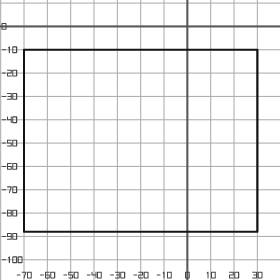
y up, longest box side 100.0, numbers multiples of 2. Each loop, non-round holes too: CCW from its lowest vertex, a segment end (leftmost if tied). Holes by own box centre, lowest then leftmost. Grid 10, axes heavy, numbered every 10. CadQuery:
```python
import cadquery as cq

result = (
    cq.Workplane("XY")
    .moveTo(-70.0, -88.0)
    .lineTo(30.0, -88.0)
    .lineTo(30.0, -10.0)
    .lineTo(-70.0, -10.0)
    .close()
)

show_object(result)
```